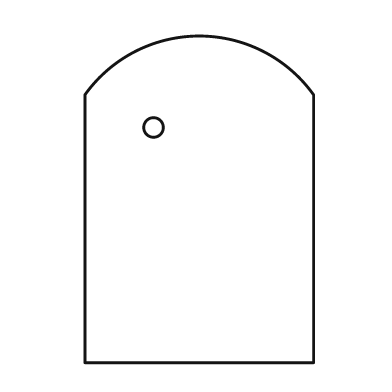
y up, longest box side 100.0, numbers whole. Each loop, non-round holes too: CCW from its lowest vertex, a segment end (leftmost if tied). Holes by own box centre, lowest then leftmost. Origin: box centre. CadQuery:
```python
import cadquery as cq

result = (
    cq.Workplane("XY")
    .moveTo(-35.0, -50.0)
    .lineTo(35.0, -50.0)
    .lineTo(35.0, 32.0)
    .threePointArc((0.0, 50.0), (-35.0, 32.0))
    .close()
    .moveTo(-14.0, 22.0)
    .circle(3.0)
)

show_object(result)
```